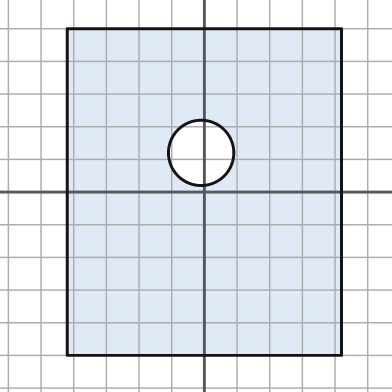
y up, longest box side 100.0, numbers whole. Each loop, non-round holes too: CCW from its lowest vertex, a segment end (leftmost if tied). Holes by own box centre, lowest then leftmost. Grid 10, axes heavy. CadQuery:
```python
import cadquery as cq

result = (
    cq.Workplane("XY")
    .moveTo(-42.0, -50.0)
    .lineTo(42.0, -50.0)
    .lineTo(42.0, 50.0)
    .lineTo(-42.0, 50.0)
    .close()
    .moveTo(-1.0, 12.0)
    .circle(10.0)
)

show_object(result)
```